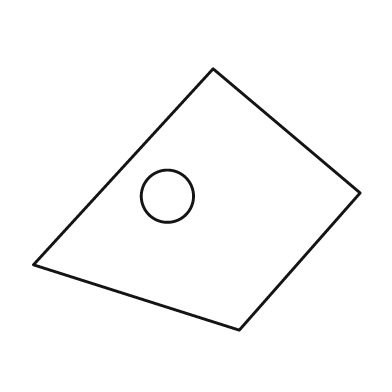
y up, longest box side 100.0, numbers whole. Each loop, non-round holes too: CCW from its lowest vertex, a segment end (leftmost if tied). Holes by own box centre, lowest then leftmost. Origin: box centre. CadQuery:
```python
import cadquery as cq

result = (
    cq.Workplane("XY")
    .moveTo(13.0, -40.0)
    .lineTo(50.0, 2.0)
    .lineTo(5.0, 40.0)
    .lineTo(-50.0, -20.0)
    .close()
    .moveTo(-9.0, 1.0)
    .circle(8.0)
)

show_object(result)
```